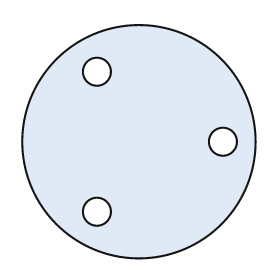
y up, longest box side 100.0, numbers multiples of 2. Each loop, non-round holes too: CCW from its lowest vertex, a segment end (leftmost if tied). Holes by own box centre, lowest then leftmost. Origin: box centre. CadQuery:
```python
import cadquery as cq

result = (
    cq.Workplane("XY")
    .moveTo(0.0, 0.0)
    .circle(50.0)
    .moveTo(-18.0, -30.0)
    .circle(6.0)
    .moveTo(36.0, 0.0)
    .circle(6.0)
    .moveTo(-18.0, 30.0)
    .circle(6.0)
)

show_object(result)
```